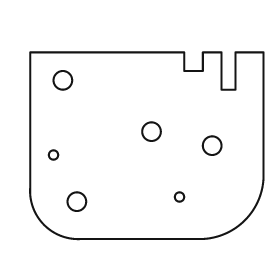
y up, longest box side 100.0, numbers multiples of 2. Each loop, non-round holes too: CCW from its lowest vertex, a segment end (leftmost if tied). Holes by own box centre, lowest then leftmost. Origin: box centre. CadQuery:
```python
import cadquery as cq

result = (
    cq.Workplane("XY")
    .moveTo(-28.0, -40.0)
    .lineTo(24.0, -40.0)
    .threePointArc((42.0, -32.0), (50.0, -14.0))
    .lineTo(50.0, 40.0)
    .lineTo(38.0, 40.0)
    .lineTo(38.0, 24.0)
    .lineTo(32.0, 24.0)
    .lineTo(32.0, 40.0)
    .lineTo(24.0, 40.0)
    .lineTo(24.0, 32.0)
    .lineTo(16.0, 32.0)
    .lineTo(16.0, 40.0)
    .lineTo(-50.0, 40.0)
    .lineTo(-50.0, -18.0)
    .threePointArc((-44.0, -34.0), (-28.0, -40.0))
    .close()
    .moveTo(-30.0, -24.0)
    .circle(4.0)
    .moveTo(14.0, -22.0)
    .circle(2.0)
    .moveTo(-40.0, -4.0)
    .circle(2.0)
    .moveTo(28.0, 0.0)
    .circle(4.0)
    .moveTo(2.0, 6.0)
    .circle(4.0)
    .moveTo(-36.0, 28.0)
    .circle(4.0)
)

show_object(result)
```